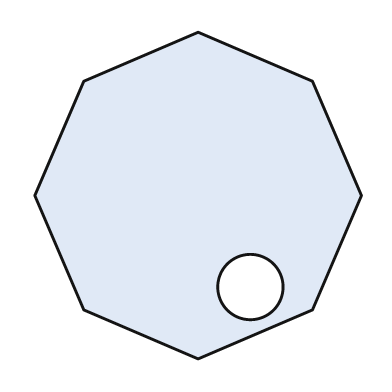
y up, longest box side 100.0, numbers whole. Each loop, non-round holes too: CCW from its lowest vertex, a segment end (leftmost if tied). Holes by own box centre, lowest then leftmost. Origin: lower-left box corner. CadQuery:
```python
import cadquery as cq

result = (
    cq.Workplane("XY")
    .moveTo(50.0, 0.0)
    .lineTo(85.0, 15.0)
    .lineTo(100.0, 50.0)
    .lineTo(85.0, 85.0)
    .lineTo(50.0, 100.0)
    .lineTo(15.0, 85.0)
    .lineTo(0.0, 50.0)
    .lineTo(15.0, 15.0)
    .close()
    .moveTo(66.0, 22.0)
    .circle(10.0)
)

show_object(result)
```